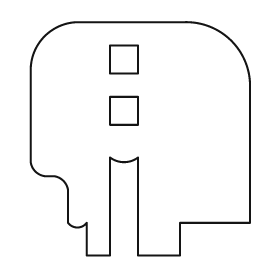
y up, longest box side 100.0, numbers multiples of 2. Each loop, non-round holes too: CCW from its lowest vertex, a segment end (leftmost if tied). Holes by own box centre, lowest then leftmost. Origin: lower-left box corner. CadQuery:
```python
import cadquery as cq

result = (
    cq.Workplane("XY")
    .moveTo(24.0, 0.0)
    .lineTo(34.0, 0.0)
    .lineTo(34.0, 42.0)
    .threePointArc((40.0, 40.0), (46.0, 42.0))
    .lineTo(46.0, 0.0)
    .lineTo(64.0, 0.0)
    .lineTo(64.0, 14.0)
    .lineTo(94.0, 14.0)
    .lineTo(94.0, 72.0)
    .threePointArc((86.0, 92.0), (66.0, 100.0))
    .lineTo(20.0, 100.0)
    .threePointArc((6.0, 94.0), (0.0, 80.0))
    .lineTo(0.0, 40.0)
    .threePointArc((2.0, 36.0), (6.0, 34.0))
    .lineTo(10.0, 34.0)
    .threePointArc((14.0, 32.0), (16.0, 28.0))
    .lineTo(16.0, 14.0)
    .threePointArc((20.0, 12.0), (24.0, 14.0))
    .close()
    .moveTo(34.0, 56.0)
    .lineTo(46.0, 56.0)
    .lineTo(46.0, 68.0)
    .lineTo(34.0, 68.0)
    .close()
    .moveTo(34.0, 78.0)
    .lineTo(46.0, 78.0)
    .lineTo(46.0, 90.0)
    .lineTo(34.0, 90.0)
    .close()
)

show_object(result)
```